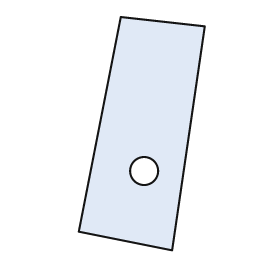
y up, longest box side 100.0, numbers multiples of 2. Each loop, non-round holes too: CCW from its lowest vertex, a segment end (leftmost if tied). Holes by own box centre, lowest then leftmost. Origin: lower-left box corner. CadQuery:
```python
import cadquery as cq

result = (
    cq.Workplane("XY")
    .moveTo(40.0, 0.0)
    .lineTo(54.0, 96.0)
    .lineTo(18.0, 100.0)
    .lineTo(0.0, 8.0)
    .close()
    .moveTo(28.0, 34.0)
    .circle(6.0)
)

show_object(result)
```